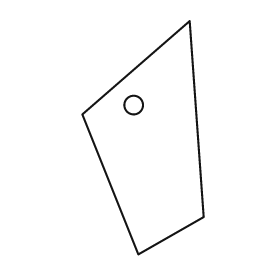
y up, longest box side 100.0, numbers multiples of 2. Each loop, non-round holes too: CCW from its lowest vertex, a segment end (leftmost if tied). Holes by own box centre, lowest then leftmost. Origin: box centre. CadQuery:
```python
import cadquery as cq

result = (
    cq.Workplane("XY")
    .moveTo(-2.0, -50.0)
    .lineTo(26.0, -34.0)
    .lineTo(20.0, 50.0)
    .lineTo(-26.0, 10.0)
    .close()
    .moveTo(-4.0, 14.0)
    .circle(4.0)
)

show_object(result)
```